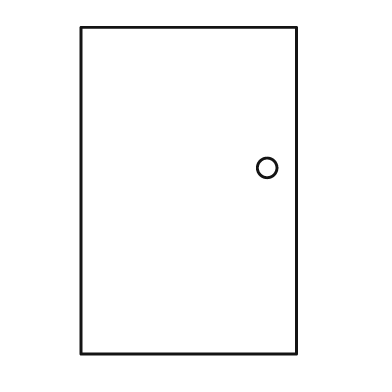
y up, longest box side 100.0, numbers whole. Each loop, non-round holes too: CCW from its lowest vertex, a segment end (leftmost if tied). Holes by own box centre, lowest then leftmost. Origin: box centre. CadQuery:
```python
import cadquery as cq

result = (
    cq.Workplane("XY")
    .moveTo(-33.0, -50.0)
    .lineTo(33.0, -50.0)
    .lineTo(33.0, 50.0)
    .lineTo(-33.0, 50.0)
    .close()
    .moveTo(24.0, 7.0)
    .circle(3.0)
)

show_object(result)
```